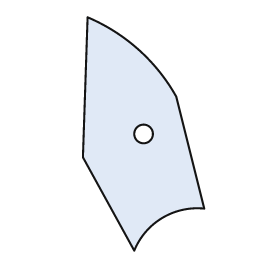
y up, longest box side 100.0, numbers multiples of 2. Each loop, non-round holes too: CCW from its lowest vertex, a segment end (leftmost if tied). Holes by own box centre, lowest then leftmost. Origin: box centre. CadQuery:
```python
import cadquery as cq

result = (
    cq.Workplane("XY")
    .moveTo(-4.0, -50.0)
    .threePointArc((8.0, -36.0), (26.0, -32.0))
    .lineTo(14.0, 16.0)
    .threePointArc((-2.0, 36.0), (-24.0, 50.0))
    .lineTo(-26.0, -10.0)
    .close()
    .moveTo(0.0, 0.0)
    .circle(4.0)
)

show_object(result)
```